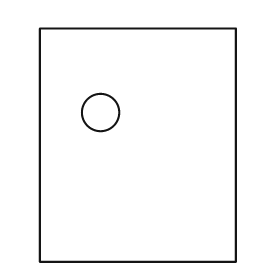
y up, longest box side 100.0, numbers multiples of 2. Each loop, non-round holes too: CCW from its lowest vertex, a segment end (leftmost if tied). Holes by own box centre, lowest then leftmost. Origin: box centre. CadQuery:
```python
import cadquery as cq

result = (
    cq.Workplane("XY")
    .moveTo(-42.0, -50.0)
    .lineTo(42.0, -50.0)
    .lineTo(42.0, 50.0)
    .lineTo(-42.0, 50.0)
    .close()
    .moveTo(-16.0, 14.0)
    .circle(8.0)
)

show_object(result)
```